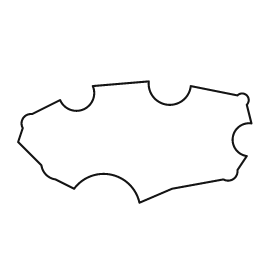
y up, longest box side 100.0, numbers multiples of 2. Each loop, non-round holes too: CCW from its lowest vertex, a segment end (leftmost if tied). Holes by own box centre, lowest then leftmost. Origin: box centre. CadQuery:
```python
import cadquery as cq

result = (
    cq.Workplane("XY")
    .moveTo(2.0, -26.0)
    .lineTo(16.0, -20.0)
    .lineTo(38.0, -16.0)
    .threePointArc((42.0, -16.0), (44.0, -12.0))
    .lineTo(48.0, -6.0)
    .threePointArc((42.0, 2.0), (50.0, 8.0))
    .lineTo(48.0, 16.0)
    .threePointArc((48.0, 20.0), (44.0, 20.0))
    .lineTo(24.0, 24.0)
    .threePointArc((14.0, 16.0), (6.0, 26.0))
    .lineTo(-18.0, 24.0)
    .threePointArc((-22.0, 14.0), (-32.0, 18.0))
    .lineTo(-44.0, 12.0)
    .threePointArc((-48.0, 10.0), (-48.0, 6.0))
    .lineTo(-50.0, 0.0)
    .lineTo(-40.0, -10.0)
    .threePointArc((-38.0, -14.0), (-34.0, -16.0))
    .lineTo(-26.0, -20.0)
    .threePointArc((-10.0, -14.0), (2.0, -26.0))
    .close()
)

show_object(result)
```